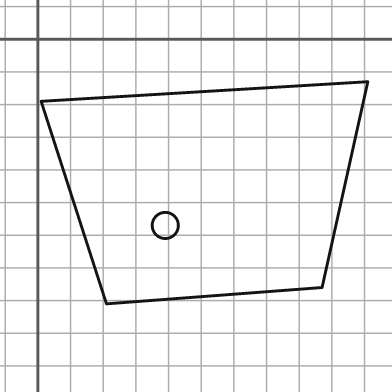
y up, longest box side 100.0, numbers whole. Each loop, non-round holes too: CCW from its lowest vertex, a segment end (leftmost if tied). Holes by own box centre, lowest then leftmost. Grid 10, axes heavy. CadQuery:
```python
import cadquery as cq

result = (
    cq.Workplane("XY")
    .moveTo(21.0, -81.0)
    .lineTo(87.0, -76.0)
    .lineTo(101.0, -13.0)
    .lineTo(1.0, -19.0)
    .close()
    .moveTo(39.0, -57.0)
    .circle(4.0)
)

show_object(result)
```